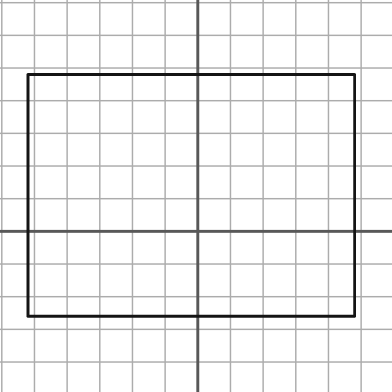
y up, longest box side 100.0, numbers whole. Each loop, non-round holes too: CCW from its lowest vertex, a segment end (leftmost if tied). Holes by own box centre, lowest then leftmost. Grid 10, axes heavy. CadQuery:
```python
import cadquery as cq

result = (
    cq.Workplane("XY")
    .moveTo(-52.0, -26.0)
    .lineTo(48.0, -26.0)
    .lineTo(48.0, 48.0)
    .lineTo(-52.0, 48.0)
    .close()
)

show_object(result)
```